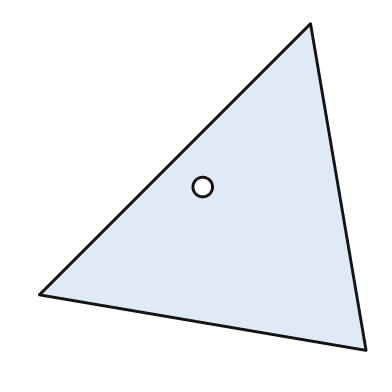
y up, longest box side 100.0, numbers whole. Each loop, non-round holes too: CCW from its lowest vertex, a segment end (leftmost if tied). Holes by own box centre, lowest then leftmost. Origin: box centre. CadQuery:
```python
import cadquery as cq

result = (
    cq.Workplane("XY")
    .moveTo(50.0, -50.0)
    .lineTo(33.0, 50.0)
    .lineTo(-50.0, -33.0)
    .close()
    .moveTo(0.0, 0.0)
    .circle(3.0)
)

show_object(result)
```